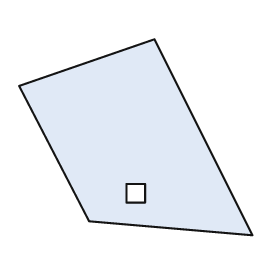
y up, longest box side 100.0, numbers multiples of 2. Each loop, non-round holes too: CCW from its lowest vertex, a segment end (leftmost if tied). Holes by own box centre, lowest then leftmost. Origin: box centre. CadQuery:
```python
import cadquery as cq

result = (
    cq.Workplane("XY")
    .moveTo(50.0, -42.0)
    .lineTo(8.0, 42.0)
    .lineTo(-50.0, 22.0)
    .lineTo(-20.0, -36.0)
    .close()
    .moveTo(-4.0, -28.0)
    .lineTo(4.0, -28.0)
    .lineTo(4.0, -20.0)
    .lineTo(-4.0, -20.0)
    .close()
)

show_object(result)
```